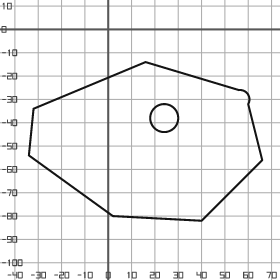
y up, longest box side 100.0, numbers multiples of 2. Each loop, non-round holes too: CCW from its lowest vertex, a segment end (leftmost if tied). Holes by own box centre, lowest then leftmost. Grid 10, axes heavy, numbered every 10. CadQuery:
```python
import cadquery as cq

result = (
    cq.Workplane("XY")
    .moveTo(40.0, -82.0)
    .lineTo(66.0, -56.0)
    .lineTo(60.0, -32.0)
    .threePointArc((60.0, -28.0), (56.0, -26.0))
    .lineTo(16.0, -14.0)
    .lineTo(-32.0, -34.0)
    .lineTo(-34.0, -54.0)
    .lineTo(2.0, -80.0)
    .close()
    .moveTo(24.0, -38.0)
    .circle(6.0)
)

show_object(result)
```